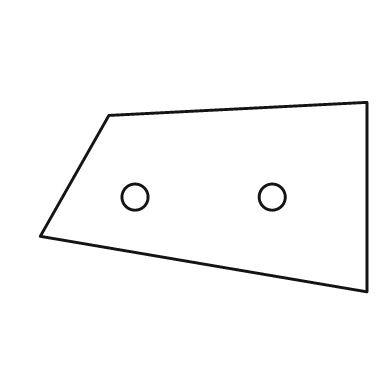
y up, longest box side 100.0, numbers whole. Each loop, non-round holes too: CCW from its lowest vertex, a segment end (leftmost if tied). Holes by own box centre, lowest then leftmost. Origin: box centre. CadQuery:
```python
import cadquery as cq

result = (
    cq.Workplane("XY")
    .moveTo(50.0, -29.0)
    .lineTo(50.0, 29.0)
    .lineTo(-29.0, 25.0)
    .lineTo(-50.0, -12.0)
    .close()
    .moveTo(-21.0, 0.0)
    .circle(4.0)
    .moveTo(21.0, 0.0)
    .circle(4.0)
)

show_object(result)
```